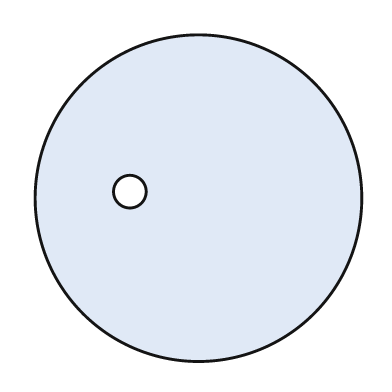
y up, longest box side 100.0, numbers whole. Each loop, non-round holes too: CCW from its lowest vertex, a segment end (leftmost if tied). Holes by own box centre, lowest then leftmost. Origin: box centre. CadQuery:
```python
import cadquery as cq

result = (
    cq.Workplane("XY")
    .moveTo(0.0, 0.0)
    .circle(50.0)
    .moveTo(-21.0, 2.0)
    .circle(5.0)
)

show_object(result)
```